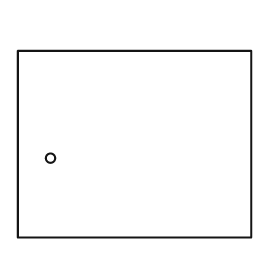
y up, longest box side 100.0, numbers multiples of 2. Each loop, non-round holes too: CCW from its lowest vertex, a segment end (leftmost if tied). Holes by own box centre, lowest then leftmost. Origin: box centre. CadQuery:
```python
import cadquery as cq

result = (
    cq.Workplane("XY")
    .moveTo(-50.0, -40.0)
    .lineTo(50.0, -40.0)
    .lineTo(50.0, 40.0)
    .lineTo(-50.0, 40.0)
    .close()
    .moveTo(-36.0, -6.0)
    .circle(2.0)
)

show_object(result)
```